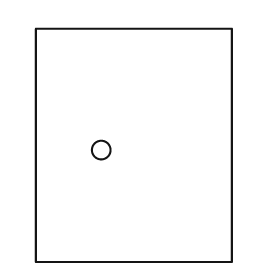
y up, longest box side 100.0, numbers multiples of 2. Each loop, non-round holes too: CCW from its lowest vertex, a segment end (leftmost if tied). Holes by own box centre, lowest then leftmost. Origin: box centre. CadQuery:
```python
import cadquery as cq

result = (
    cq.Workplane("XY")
    .moveTo(-42.0, -50.0)
    .lineTo(42.0, -50.0)
    .lineTo(42.0, 50.0)
    .lineTo(-42.0, 50.0)
    .close()
    .moveTo(-14.0, -2.0)
    .circle(4.0)
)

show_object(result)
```